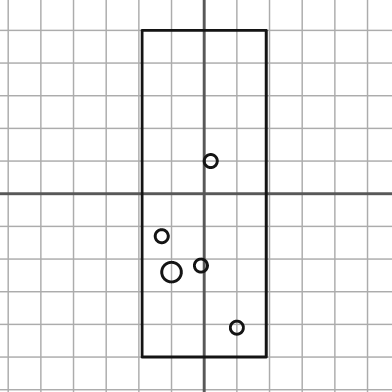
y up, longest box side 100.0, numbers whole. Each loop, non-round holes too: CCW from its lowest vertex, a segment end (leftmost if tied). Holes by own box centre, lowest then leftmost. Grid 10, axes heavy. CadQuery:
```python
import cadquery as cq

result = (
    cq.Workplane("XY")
    .moveTo(-19.0, -50.0)
    .lineTo(19.0, -50.0)
    .lineTo(19.0, 50.0)
    .lineTo(-19.0, 50.0)
    .close()
    .moveTo(10.0, -41.0)
    .circle(2.0)
    .moveTo(-10.0, -24.0)
    .circle(3.0)
    .moveTo(-1.0, -22.0)
    .circle(2.0)
    .moveTo(-13.0, -13.0)
    .circle(2.0)
    .moveTo(2.0, 10.0)
    .circle(2.0)
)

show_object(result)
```